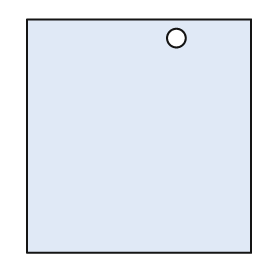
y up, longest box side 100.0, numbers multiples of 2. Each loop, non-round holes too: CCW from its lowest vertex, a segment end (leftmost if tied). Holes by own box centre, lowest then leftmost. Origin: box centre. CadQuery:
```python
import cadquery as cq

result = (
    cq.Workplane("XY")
    .moveTo(-48.0, -50.0)
    .lineTo(48.0, -50.0)
    .lineTo(48.0, 50.0)
    .lineTo(-48.0, 50.0)
    .close()
    .moveTo(16.0, 42.0)
    .circle(4.0)
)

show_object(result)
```